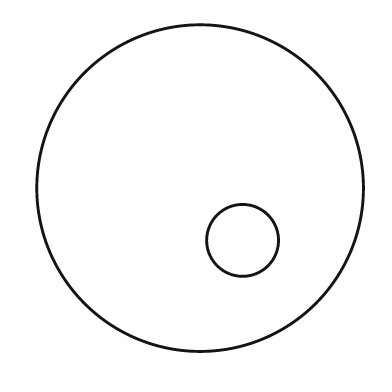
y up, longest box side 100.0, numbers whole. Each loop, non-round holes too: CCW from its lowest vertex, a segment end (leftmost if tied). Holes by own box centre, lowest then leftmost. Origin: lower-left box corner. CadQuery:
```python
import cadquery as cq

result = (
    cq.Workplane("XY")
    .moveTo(50.0, 50.0)
    .circle(50.0)
    .moveTo(63.0, 34.0)
    .circle(11.0)
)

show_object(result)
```